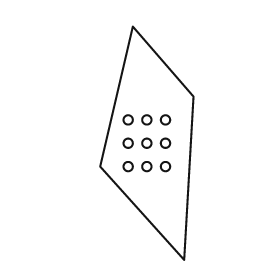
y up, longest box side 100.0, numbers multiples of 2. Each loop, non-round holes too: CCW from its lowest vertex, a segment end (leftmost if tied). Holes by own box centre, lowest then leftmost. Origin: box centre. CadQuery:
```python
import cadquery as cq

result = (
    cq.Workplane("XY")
    .moveTo(16.0, -50.0)
    .lineTo(20.0, 20.0)
    .lineTo(-6.0, 50.0)
    .lineTo(-20.0, -10.0)
    .close()
    .moveTo(-8.0, -10.0)
    .circle(2.0)
    .moveTo(0.0, -10.0)
    .circle(2.0)
    .moveTo(8.0, -10.0)
    .circle(2.0)
    .moveTo(-8.0, 0.0)
    .circle(2.0)
    .moveTo(0.0, 0.0)
    .circle(2.0)
    .moveTo(8.0, 0.0)
    .circle(2.0)
    .moveTo(-8.0, 10.0)
    .circle(2.0)
    .moveTo(0.0, 10.0)
    .circle(2.0)
    .moveTo(8.0, 10.0)
    .circle(2.0)
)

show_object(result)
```